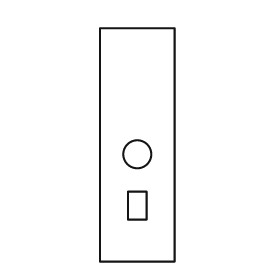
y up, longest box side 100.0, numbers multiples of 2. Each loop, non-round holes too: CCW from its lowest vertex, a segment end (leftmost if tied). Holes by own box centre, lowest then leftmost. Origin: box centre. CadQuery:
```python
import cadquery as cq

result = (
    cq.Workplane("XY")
    .moveTo(-16.0, -50.0)
    .lineTo(16.0, -50.0)
    .lineTo(16.0, 50.0)
    .lineTo(-16.0, 50.0)
    .close()
    .moveTo(-4.0, -32.0)
    .lineTo(4.0, -32.0)
    .lineTo(4.0, -20.0)
    .lineTo(-4.0, -20.0)
    .close()
    .moveTo(0.0, -4.0)
    .circle(6.0)
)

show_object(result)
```